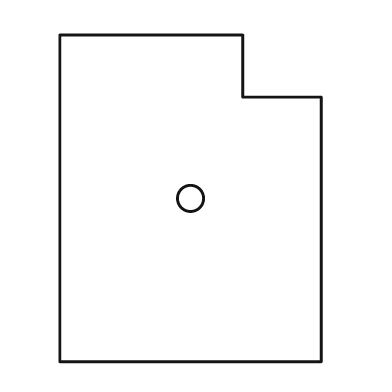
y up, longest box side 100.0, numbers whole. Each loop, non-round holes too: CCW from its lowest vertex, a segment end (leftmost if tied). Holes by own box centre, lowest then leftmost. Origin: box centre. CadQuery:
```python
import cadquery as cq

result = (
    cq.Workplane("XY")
    .moveTo(-40.0, -50.0)
    .lineTo(40.0, -50.0)
    .lineTo(40.0, 31.0)
    .lineTo(16.0, 31.0)
    .lineTo(16.0, 50.0)
    .lineTo(-40.0, 50.0)
    .close()
    .moveTo(0.0, 0.0)
    .circle(4.0)
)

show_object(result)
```